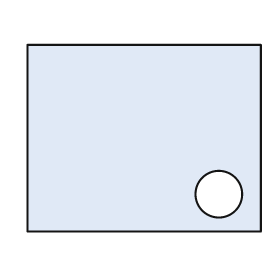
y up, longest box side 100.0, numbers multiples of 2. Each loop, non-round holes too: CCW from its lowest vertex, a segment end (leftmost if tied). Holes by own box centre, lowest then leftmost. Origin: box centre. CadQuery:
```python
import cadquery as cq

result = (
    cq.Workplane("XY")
    .moveTo(-50.0, -40.0)
    .lineTo(50.0, -40.0)
    .lineTo(50.0, 40.0)
    .lineTo(-50.0, 40.0)
    .close()
    .moveTo(32.0, -24.0)
    .circle(10.0)
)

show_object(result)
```